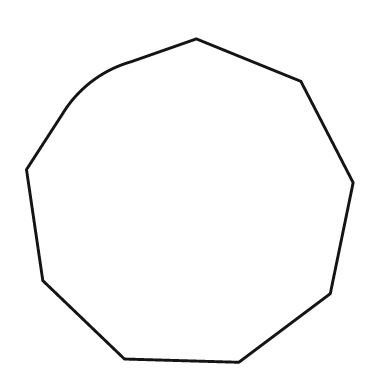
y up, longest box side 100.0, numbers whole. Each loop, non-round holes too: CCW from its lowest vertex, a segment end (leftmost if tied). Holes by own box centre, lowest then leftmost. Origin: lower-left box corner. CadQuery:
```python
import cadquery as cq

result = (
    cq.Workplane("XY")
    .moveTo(65.0, 0.0)
    .lineTo(93.0, 21.0)
    .lineTo(100.0, 55.0)
    .lineTo(84.0, 86.0)
    .lineTo(52.0, 99.0)
    .lineTo(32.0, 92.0)
    .threePointArc((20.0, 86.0), (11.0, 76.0))
    .lineTo(0.0, 59.0)
    .lineTo(5.0, 25.0)
    .lineTo(30.0, 1.0)
    .close()
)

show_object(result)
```